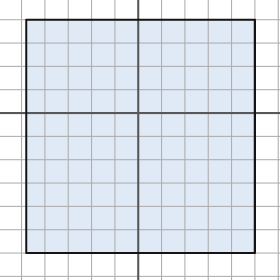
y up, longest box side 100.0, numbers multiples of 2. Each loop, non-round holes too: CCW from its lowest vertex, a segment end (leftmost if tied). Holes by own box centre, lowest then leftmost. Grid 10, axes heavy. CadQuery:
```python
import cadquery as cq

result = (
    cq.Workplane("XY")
    .moveTo(-48.0, -60.0)
    .lineTo(50.0, -60.0)
    .lineTo(50.0, 40.0)
    .lineTo(-48.0, 40.0)
    .close()
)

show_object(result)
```